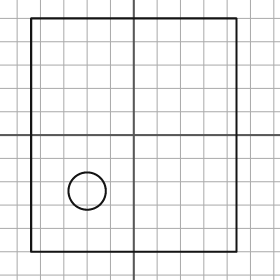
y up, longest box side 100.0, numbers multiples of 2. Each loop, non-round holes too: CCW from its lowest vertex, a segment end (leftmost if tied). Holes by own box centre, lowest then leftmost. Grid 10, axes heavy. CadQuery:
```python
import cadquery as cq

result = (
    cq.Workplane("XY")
    .moveTo(-44.0, -50.0)
    .lineTo(44.0, -50.0)
    .lineTo(44.0, 50.0)
    .lineTo(-44.0, 50.0)
    .close()
    .moveTo(-20.0, -24.0)
    .circle(8.0)
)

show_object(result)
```